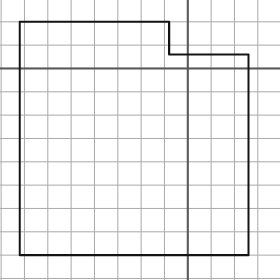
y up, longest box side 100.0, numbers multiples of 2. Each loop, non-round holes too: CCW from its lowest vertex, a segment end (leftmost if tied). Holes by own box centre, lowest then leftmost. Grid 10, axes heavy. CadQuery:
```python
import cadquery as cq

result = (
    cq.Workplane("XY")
    .moveTo(-72.0, -80.0)
    .lineTo(26.0, -80.0)
    .lineTo(26.0, 6.0)
    .lineTo(-8.0, 6.0)
    .lineTo(-8.0, 20.0)
    .lineTo(-72.0, 20.0)
    .close()
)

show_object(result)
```